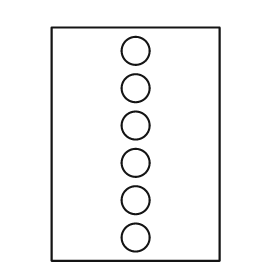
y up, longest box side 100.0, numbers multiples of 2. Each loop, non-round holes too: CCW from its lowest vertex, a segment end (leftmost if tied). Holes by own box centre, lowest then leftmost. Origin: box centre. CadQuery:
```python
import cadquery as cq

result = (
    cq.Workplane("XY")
    .moveTo(-36.0, -50.0)
    .lineTo(36.0, -50.0)
    .lineTo(36.0, 50.0)
    .lineTo(-36.0, 50.0)
    .close()
    .moveTo(0.0, -40.0)
    .circle(6.0)
    .moveTo(0.0, -24.0)
    .circle(6.0)
    .moveTo(0.0, -8.0)
    .circle(6.0)
    .moveTo(0.0, 8.0)
    .circle(6.0)
    .moveTo(0.0, 24.0)
    .circle(6.0)
    .moveTo(0.0, 40.0)
    .circle(6.0)
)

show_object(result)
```